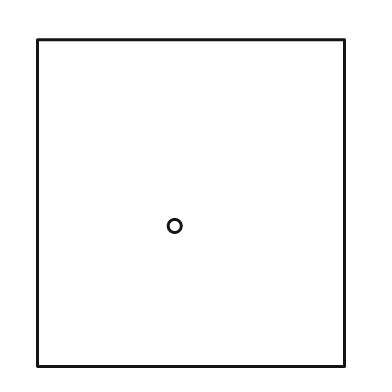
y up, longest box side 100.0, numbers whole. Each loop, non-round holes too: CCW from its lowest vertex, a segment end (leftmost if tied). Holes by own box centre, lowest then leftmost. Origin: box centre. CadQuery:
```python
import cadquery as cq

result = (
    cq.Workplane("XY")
    .moveTo(-47.0, -50.0)
    .lineTo(47.0, -50.0)
    .lineTo(47.0, 50.0)
    .lineTo(-47.0, 50.0)
    .close()
    .moveTo(-5.0, -7.0)
    .circle(2.0)
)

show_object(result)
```